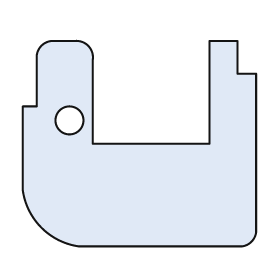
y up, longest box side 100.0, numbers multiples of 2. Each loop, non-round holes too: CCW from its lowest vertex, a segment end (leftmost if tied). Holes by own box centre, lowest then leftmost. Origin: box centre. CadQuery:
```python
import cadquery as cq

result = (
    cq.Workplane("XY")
    .moveTo(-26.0, -44.0)
    .lineTo(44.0, -44.0)
    .threePointArc((48.0, -42.0), (50.0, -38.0))
    .lineTo(50.0, 30.0)
    .lineTo(42.0, 30.0)
    .lineTo(42.0, 44.0)
    .lineTo(30.0, 44.0)
    .lineTo(30.0, 0.0)
    .lineTo(-20.0, 0.0)
    .lineTo(-20.0, 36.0)
    .threePointArc((-22.0, 42.0), (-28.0, 44.0))
    .lineTo(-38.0, 44.0)
    .threePointArc((-42.0, 42.0), (-44.0, 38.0))
    .lineTo(-44.0, 16.0)
    .lineTo(-50.0, 16.0)
    .lineTo(-50.0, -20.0)
    .threePointArc((-42.0, -36.0), (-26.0, -44.0))
    .close()
    .moveTo(-30.0, 10.0)
    .circle(6.0)
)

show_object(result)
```